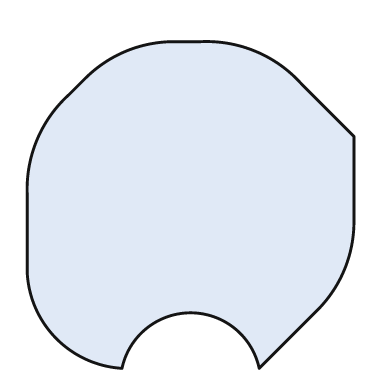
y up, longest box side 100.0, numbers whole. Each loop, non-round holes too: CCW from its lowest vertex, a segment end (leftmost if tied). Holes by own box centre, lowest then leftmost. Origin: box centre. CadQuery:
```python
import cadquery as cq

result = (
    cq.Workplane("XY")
    .moveTo(-21.0, -50.0)
    .threePointArc((0.0, -33.0), (21.0, -50.0))
    .lineTo(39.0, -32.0)
    .threePointArc((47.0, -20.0), (50.0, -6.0))
    .lineTo(50.0, 21.0)
    .lineTo(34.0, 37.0)
    .threePointArc((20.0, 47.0), (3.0, 50.0))
    .lineTo(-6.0, 50.0)
    .threePointArc((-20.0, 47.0), (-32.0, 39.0))
    .lineTo(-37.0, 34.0)
    .threePointArc((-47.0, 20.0), (-50.0, 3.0))
    .lineTo(-50.0, -21.0)
    .threePointArc((-41.0, -41.0), (-21.0, -50.0))
    .close()
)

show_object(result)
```